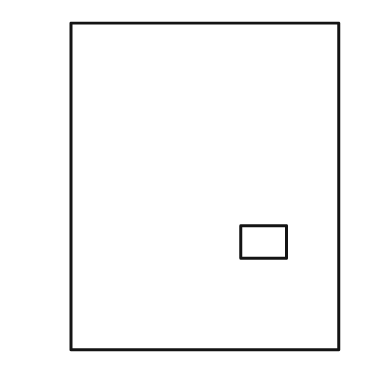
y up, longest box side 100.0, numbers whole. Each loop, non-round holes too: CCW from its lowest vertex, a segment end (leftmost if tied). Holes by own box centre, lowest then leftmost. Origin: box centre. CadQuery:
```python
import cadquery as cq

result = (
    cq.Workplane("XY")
    .moveTo(-41.0, -50.0)
    .lineTo(41.0, -50.0)
    .lineTo(41.0, 50.0)
    .lineTo(-41.0, 50.0)
    .close()
    .moveTo(11.0, -22.0)
    .lineTo(25.0, -22.0)
    .lineTo(25.0, -12.0)
    .lineTo(11.0, -12.0)
    .close()
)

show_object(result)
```